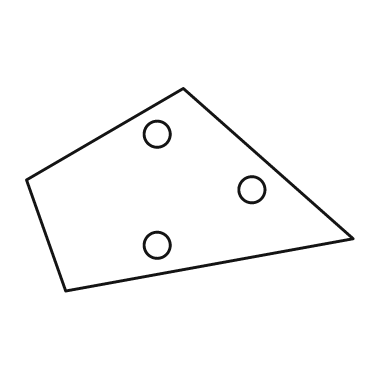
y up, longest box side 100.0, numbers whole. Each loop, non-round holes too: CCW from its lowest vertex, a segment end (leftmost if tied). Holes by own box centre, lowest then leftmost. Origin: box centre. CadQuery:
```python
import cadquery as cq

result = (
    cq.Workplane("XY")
    .moveTo(-38.0, -31.0)
    .lineTo(50.0, -15.0)
    .lineTo(-2.0, 31.0)
    .lineTo(-50.0, 3.0)
    .close()
    .moveTo(-10.0, -17.0)
    .circle(4.0)
    .moveTo(19.0, 0.0)
    .circle(4.0)
    .moveTo(-10.0, 17.0)
    .circle(4.0)
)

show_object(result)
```